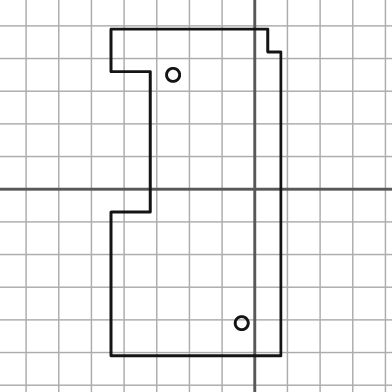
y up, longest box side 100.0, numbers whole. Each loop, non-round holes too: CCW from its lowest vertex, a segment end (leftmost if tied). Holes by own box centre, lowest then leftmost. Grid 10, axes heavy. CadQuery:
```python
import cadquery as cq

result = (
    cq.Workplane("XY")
    .moveTo(-44.0, -51.0)
    .lineTo(8.0, -51.0)
    .lineTo(8.0, 42.0)
    .lineTo(4.0, 42.0)
    .lineTo(4.0, 49.0)
    .lineTo(-44.0, 49.0)
    .lineTo(-44.0, 36.0)
    .lineTo(-32.0, 36.0)
    .lineTo(-32.0, -7.0)
    .lineTo(-44.0, -7.0)
    .close()
    .moveTo(-4.0, -41.0)
    .circle(2.0)
    .moveTo(-25.0, 35.0)
    .circle(2.0)
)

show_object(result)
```